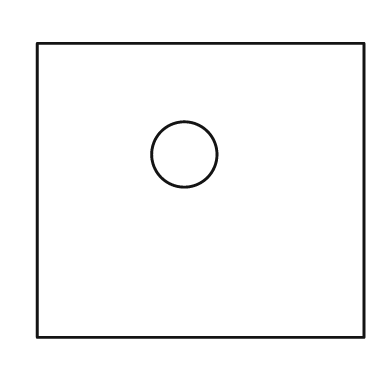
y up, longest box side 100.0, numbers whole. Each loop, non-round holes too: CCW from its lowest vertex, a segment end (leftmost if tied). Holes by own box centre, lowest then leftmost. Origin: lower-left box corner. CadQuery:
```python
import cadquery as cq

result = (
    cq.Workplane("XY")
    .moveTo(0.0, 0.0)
    .lineTo(100.0, 0.0)
    .lineTo(100.0, 90.0)
    .lineTo(0.0, 90.0)
    .close()
    .moveTo(45.0, 56.0)
    .circle(10.0)
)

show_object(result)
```